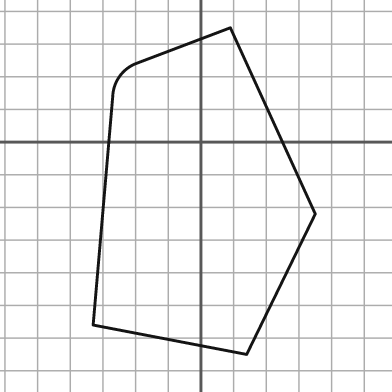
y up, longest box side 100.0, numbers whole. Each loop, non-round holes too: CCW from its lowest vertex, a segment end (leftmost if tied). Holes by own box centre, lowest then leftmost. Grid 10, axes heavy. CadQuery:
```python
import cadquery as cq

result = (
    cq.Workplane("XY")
    .moveTo(14.0, -65.0)
    .lineTo(35.0, -22.0)
    .lineTo(9.0, 35.0)
    .lineTo(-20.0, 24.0)
    .threePointArc((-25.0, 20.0), (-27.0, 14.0))
    .lineTo(-33.0, -56.0)
    .close()
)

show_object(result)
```